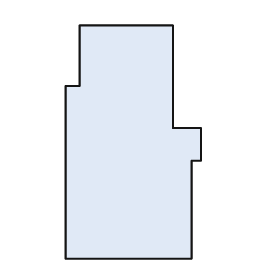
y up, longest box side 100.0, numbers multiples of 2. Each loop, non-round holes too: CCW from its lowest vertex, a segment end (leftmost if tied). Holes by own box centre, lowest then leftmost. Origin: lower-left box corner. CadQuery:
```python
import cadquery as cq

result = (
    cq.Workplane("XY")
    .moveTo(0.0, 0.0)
    .lineTo(54.0, 0.0)
    .lineTo(54.0, 42.0)
    .lineTo(58.0, 42.0)
    .lineTo(58.0, 56.0)
    .lineTo(46.0, 56.0)
    .lineTo(46.0, 100.0)
    .lineTo(6.0, 100.0)
    .lineTo(6.0, 74.0)
    .lineTo(0.0, 74.0)
    .close()
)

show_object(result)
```